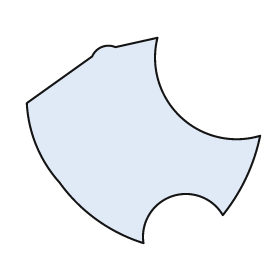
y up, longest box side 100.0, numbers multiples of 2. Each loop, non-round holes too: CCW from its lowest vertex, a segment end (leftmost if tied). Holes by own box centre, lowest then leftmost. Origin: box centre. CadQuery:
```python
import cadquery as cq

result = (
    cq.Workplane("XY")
    .moveTo(0.0, -44.0)
    .threePointArc((12.0, -24.0), (34.0, -32.0))
    .threePointArc((44.0, -16.0), (50.0, 2.0))
    .threePointArc((16.0, 10.0), (6.0, 44.0))
    .lineTo(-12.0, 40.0)
    .threePointArc((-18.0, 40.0), (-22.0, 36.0))
    .lineTo(-50.0, 16.0)
    .threePointArc((-46.0, -2.0), (-36.0, -18.0))
    .threePointArc((-20.0, -34.0), (0.0, -44.0))
    .close()
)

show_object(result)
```